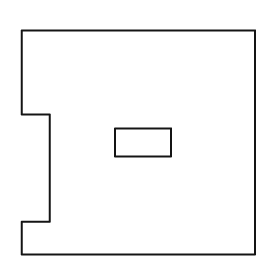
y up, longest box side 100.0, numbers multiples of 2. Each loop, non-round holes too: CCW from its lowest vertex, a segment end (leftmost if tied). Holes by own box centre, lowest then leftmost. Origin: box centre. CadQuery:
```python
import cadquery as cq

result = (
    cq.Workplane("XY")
    .moveTo(-50.0, -48.0)
    .lineTo(50.0, -48.0)
    .lineTo(50.0, 48.0)
    .lineTo(-50.0, 48.0)
    .lineTo(-50.0, 12.0)
    .lineTo(-38.0, 12.0)
    .lineTo(-38.0, -34.0)
    .lineTo(-50.0, -34.0)
    .close()
    .moveTo(-10.0, -6.0)
    .lineTo(14.0, -6.0)
    .lineTo(14.0, 6.0)
    .lineTo(-10.0, 6.0)
    .close()
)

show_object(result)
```